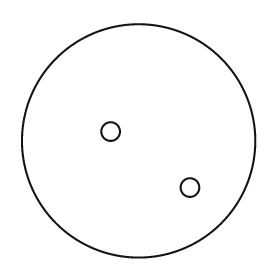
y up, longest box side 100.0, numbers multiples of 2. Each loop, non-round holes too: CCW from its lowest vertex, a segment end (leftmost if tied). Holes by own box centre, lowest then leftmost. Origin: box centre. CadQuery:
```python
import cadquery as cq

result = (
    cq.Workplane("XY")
    .moveTo(0.0, 0.0)
    .circle(50.0)
    .moveTo(22.0, -20.0)
    .circle(4.0)
    .moveTo(-12.0, 4.0)
    .circle(4.0)
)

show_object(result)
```